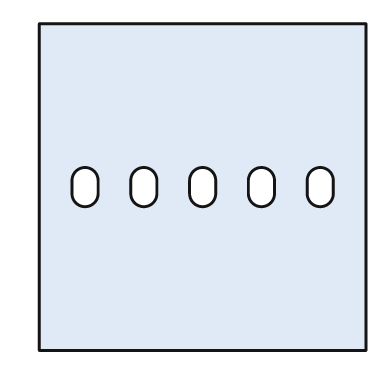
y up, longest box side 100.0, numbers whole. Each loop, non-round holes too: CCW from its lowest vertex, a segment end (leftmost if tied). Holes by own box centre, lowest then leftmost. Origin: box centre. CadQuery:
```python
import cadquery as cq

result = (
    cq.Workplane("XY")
    .moveTo(-50.0, -50.0)
    .lineTo(50.0, -50.0)
    .lineTo(50.0, 50.0)
    .lineTo(-50.0, 50.0)
    .close()
    .moveTo(-40.0, -2.0)
    .threePointArc((-36.0, -6.0), (-32.0, -2.0))
    .lineTo(-32.0, 2.0)
    .threePointArc((-36.0, 6.0), (-40.0, 2.0))
    .close()
    .moveTo(-22.0, -2.0)
    .threePointArc((-18.0, -6.0), (-14.0, -2.0))
    .lineTo(-14.0, 2.0)
    .threePointArc((-18.0, 6.0), (-22.0, 2.0))
    .close()
    .moveTo(-4.0, -2.0)
    .threePointArc((0.0, -6.0), (4.0, -2.0))
    .lineTo(4.0, 2.0)
    .threePointArc((0.0, 6.0), (-4.0, 2.0))
    .close()
    .moveTo(14.0, -2.0)
    .threePointArc((18.0, -6.0), (22.0, -2.0))
    .lineTo(22.0, 2.0)
    .threePointArc((18.0, 6.0), (14.0, 2.0))
    .close()
    .moveTo(32.0, -2.0)
    .threePointArc((36.0, -6.0), (40.0, -2.0))
    .lineTo(40.0, 2.0)
    .threePointArc((36.0, 6.0), (32.0, 2.0))
    .close()
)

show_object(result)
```